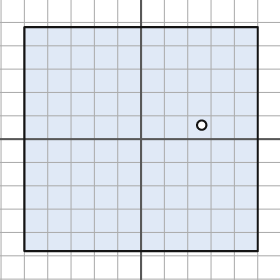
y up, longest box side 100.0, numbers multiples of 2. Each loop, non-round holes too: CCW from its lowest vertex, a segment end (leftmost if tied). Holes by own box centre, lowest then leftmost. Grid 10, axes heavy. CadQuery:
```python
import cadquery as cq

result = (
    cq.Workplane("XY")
    .moveTo(-50.0, -48.0)
    .lineTo(50.0, -48.0)
    .lineTo(50.0, 48.0)
    .lineTo(-50.0, 48.0)
    .close()
    .moveTo(26.0, 6.0)
    .circle(2.0)
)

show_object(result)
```